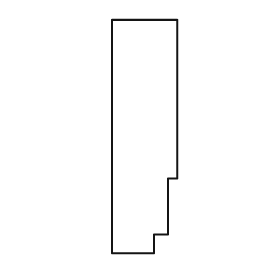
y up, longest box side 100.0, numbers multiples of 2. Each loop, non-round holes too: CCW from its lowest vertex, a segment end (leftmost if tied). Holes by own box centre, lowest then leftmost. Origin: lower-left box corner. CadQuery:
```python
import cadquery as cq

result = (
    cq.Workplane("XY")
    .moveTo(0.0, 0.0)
    .lineTo(18.0, 0.0)
    .lineTo(18.0, 8.0)
    .lineTo(24.0, 8.0)
    .lineTo(24.0, 32.0)
    .lineTo(28.0, 32.0)
    .lineTo(28.0, 100.0)
    .lineTo(0.0, 100.0)
    .close()
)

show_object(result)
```